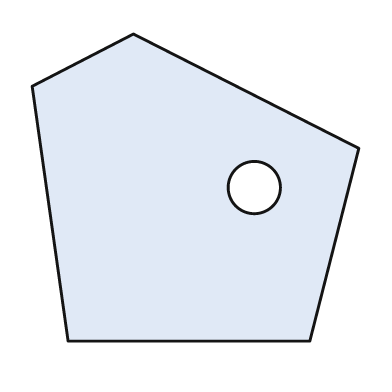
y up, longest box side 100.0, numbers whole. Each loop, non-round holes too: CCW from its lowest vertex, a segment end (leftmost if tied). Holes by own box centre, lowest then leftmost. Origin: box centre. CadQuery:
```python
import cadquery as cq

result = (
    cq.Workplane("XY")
    .moveTo(-39.0, -47.0)
    .lineTo(35.0, -47.0)
    .lineTo(50.0, 12.0)
    .lineTo(-19.0, 47.0)
    .lineTo(-50.0, 31.0)
    .close()
    .moveTo(18.0, 0.0)
    .circle(8.0)
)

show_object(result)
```